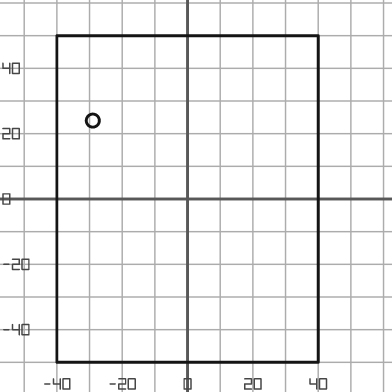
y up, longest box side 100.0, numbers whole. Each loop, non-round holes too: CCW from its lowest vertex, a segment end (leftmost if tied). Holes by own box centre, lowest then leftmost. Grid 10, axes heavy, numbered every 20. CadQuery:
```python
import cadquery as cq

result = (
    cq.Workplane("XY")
    .moveTo(-40.0, -50.0)
    .lineTo(40.0, -50.0)
    .lineTo(40.0, 50.0)
    .lineTo(-40.0, 50.0)
    .close()
    .moveTo(-29.0, 24.0)
    .circle(2.0)
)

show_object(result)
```